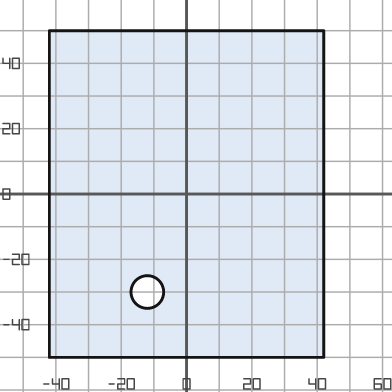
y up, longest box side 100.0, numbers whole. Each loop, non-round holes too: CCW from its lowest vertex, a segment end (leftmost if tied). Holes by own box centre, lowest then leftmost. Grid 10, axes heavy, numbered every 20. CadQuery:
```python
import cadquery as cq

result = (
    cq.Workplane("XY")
    .moveTo(-42.0, -50.0)
    .lineTo(42.0, -50.0)
    .lineTo(42.0, 50.0)
    .lineTo(-42.0, 50.0)
    .close()
    .moveTo(-12.0, -30.0)
    .circle(5.0)
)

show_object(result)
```